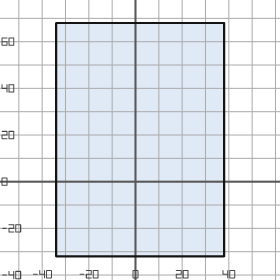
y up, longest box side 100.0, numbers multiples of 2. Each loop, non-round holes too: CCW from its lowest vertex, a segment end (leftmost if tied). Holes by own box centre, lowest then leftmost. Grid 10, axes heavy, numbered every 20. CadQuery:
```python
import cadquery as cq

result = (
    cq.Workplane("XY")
    .moveTo(-34.0, -32.0)
    .lineTo(38.0, -32.0)
    .lineTo(38.0, 68.0)
    .lineTo(-34.0, 68.0)
    .close()
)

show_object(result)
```